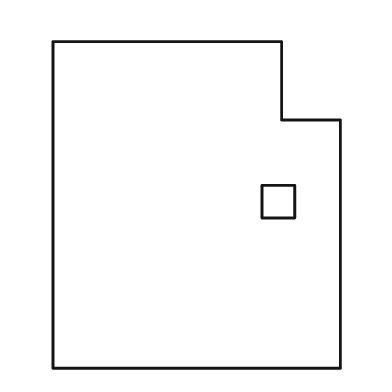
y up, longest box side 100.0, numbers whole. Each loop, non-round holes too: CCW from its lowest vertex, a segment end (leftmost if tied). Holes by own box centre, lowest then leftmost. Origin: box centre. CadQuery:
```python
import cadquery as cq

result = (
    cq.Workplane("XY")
    .moveTo(-44.0, -50.0)
    .lineTo(44.0, -50.0)
    .lineTo(44.0, 26.0)
    .lineTo(26.0, 26.0)
    .lineTo(26.0, 50.0)
    .lineTo(-44.0, 50.0)
    .close()
    .moveTo(20.0, -4.0)
    .lineTo(30.0, -4.0)
    .lineTo(30.0, 6.0)
    .lineTo(20.0, 6.0)
    .close()
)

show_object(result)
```